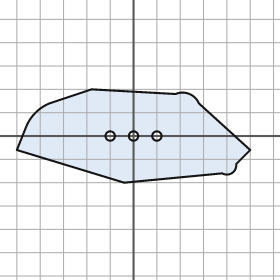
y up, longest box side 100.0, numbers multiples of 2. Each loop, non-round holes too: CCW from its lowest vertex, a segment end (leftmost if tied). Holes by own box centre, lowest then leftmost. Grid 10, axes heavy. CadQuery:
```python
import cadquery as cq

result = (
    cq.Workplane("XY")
    .moveTo(-4.0, -20.0)
    .lineTo(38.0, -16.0)
    .threePointArc((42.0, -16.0), (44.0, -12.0))
    .lineTo(50.0, -6.0)
    .lineTo(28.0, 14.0)
    .threePointArc((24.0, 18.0), (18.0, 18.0))
    .lineTo(-18.0, 20.0)
    .lineTo(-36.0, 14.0)
    .threePointArc((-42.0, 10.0), (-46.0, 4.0))
    .lineTo(-50.0, -6.0)
    .close()
    .moveTo(-10.0, 0.0)
    .circle(2.0)
    .moveTo(0.0, 0.0)
    .circle(2.0)
    .moveTo(10.0, 0.0)
    .circle(2.0)
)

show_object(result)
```